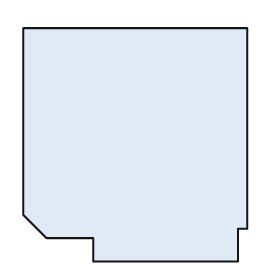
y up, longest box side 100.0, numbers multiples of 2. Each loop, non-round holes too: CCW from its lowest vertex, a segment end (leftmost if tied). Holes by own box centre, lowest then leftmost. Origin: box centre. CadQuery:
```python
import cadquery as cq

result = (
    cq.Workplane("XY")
    .moveTo(-18.0, -50.0)
    .lineTo(44.0, -50.0)
    .lineTo(44.0, -36.0)
    .lineTo(48.0, -36.0)
    .lineTo(48.0, 50.0)
    .lineTo(-48.0, 50.0)
    .lineTo(-48.0, -30.0)
    .lineTo(-38.0, -40.0)
    .lineTo(-18.0, -40.0)
    .close()
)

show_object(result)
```